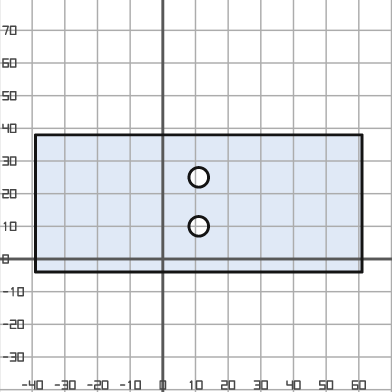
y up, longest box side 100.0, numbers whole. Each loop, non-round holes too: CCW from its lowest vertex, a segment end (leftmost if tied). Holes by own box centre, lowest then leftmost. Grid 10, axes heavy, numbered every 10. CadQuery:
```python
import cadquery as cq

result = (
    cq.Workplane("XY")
    .moveTo(-39.0, -4.0)
    .lineTo(61.0, -4.0)
    .lineTo(61.0, 38.0)
    .lineTo(-39.0, 38.0)
    .close()
    .moveTo(11.0, 10.0)
    .circle(3.0)
    .moveTo(11.0, 25.0)
    .circle(3.0)
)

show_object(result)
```